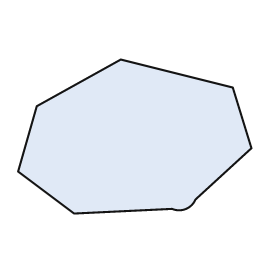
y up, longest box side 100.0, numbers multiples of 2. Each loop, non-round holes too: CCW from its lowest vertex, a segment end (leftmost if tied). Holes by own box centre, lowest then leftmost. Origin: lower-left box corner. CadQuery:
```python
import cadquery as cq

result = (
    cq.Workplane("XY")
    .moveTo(24.0, 0.0)
    .lineTo(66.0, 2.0)
    .threePointArc((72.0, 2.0), (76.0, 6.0))
    .lineTo(100.0, 28.0)
    .lineTo(92.0, 54.0)
    .lineTo(44.0, 66.0)
    .lineTo(8.0, 46.0)
    .lineTo(0.0, 18.0)
    .close()
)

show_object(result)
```